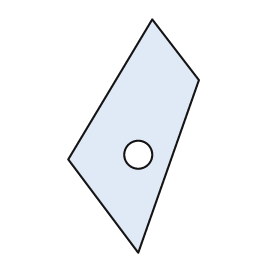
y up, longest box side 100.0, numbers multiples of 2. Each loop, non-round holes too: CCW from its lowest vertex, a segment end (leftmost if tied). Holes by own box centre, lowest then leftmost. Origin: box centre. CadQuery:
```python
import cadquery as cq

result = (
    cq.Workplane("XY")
    .moveTo(2.0, -50.0)
    .lineTo(28.0, 24.0)
    .lineTo(8.0, 50.0)
    .lineTo(-28.0, -10.0)
    .close()
    .moveTo(2.0, -8.0)
    .circle(6.0)
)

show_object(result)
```